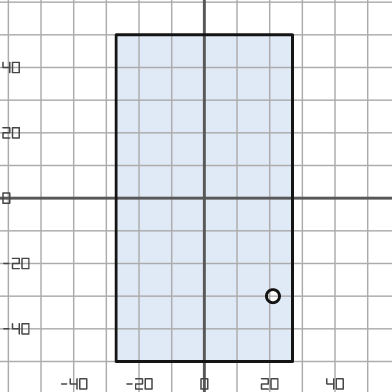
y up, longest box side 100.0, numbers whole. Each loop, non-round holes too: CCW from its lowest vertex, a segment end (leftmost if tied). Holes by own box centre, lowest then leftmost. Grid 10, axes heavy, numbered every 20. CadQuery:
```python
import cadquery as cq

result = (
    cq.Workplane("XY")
    .moveTo(-27.0, -50.0)
    .lineTo(27.0, -50.0)
    .lineTo(27.0, 50.0)
    .lineTo(-27.0, 50.0)
    .close()
    .moveTo(21.0, -30.0)
    .circle(2.0)
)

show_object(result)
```